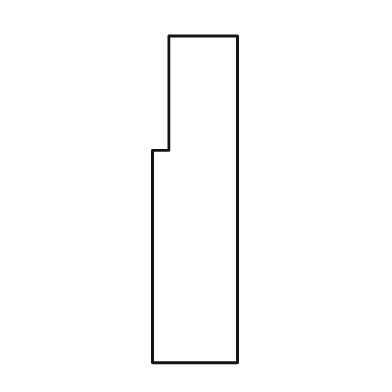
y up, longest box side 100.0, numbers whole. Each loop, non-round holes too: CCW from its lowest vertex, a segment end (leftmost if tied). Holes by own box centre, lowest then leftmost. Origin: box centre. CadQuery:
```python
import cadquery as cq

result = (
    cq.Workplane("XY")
    .moveTo(-13.0, -50.0)
    .lineTo(13.0, -50.0)
    .lineTo(13.0, 50.0)
    .lineTo(-8.0, 50.0)
    .lineTo(-8.0, 15.0)
    .lineTo(-13.0, 15.0)
    .close()
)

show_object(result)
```